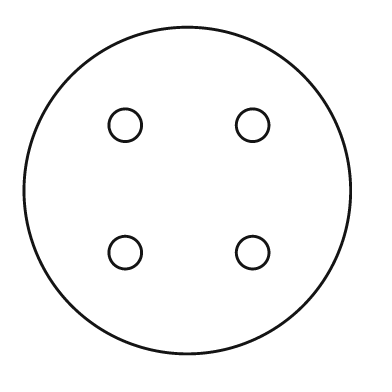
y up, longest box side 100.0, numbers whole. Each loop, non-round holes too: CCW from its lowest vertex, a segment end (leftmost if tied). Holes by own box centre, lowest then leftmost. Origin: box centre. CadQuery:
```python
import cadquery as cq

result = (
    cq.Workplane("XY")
    .moveTo(0.0, 0.0)
    .circle(50.0)
    .moveTo(-19.0, -19.0)
    .circle(5.0)
    .moveTo(20.0, -19.0)
    .circle(5.0)
    .moveTo(-19.0, 20.0)
    .circle(5.0)
    .moveTo(20.0, 20.0)
    .circle(5.0)
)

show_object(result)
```